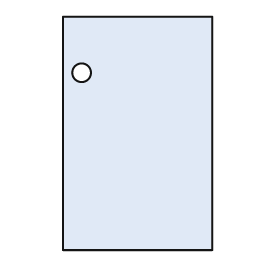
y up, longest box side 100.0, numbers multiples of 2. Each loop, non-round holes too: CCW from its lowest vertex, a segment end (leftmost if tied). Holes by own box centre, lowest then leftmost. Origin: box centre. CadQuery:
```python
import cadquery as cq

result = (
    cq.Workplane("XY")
    .moveTo(-32.0, -50.0)
    .lineTo(32.0, -50.0)
    .lineTo(32.0, 50.0)
    .lineTo(-32.0, 50.0)
    .close()
    .moveTo(-24.0, 26.0)
    .circle(4.0)
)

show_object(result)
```